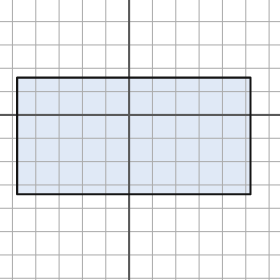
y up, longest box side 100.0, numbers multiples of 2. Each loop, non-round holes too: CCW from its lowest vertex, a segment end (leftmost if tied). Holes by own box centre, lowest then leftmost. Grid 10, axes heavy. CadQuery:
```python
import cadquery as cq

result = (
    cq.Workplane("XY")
    .moveTo(-48.0, -34.0)
    .lineTo(52.0, -34.0)
    .lineTo(52.0, 16.0)
    .lineTo(-48.0, 16.0)
    .close()
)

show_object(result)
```